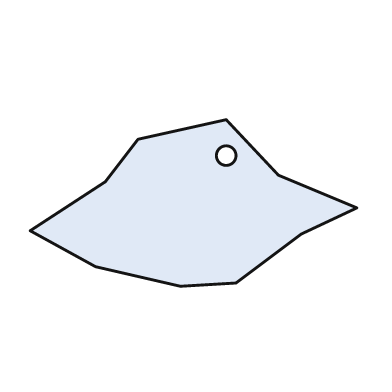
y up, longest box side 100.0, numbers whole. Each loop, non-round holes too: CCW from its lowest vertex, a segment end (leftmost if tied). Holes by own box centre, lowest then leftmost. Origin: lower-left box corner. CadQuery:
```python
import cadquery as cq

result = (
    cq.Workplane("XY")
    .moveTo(46.0, 0.0)
    .lineTo(63.0, 1.0)
    .lineTo(83.0, 16.0)
    .lineTo(100.0, 24.0)
    .lineTo(76.0, 34.0)
    .lineTo(60.0, 51.0)
    .lineTo(33.0, 45.0)
    .lineTo(23.0, 32.0)
    .lineTo(0.0, 17.0)
    .lineTo(20.0, 6.0)
    .close()
    .moveTo(60.0, 40.0)
    .circle(3.0)
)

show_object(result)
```